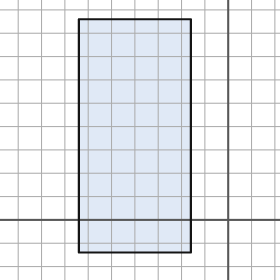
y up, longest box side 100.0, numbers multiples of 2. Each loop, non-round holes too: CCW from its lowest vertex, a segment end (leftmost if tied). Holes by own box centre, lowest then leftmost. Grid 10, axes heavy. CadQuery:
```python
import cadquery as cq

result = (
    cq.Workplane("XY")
    .moveTo(-64.0, -14.0)
    .lineTo(-16.0, -14.0)
    .lineTo(-16.0, 86.0)
    .lineTo(-64.0, 86.0)
    .close()
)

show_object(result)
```